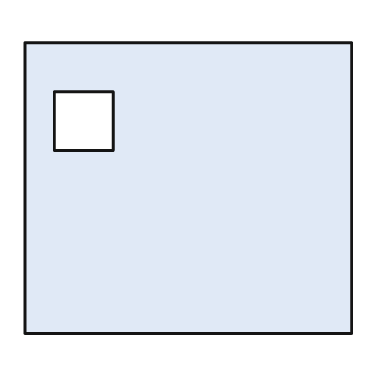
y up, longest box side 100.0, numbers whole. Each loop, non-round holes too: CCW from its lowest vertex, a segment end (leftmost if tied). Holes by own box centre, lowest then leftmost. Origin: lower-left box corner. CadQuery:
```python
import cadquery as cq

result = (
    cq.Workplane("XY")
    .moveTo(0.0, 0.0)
    .lineTo(100.0, 0.0)
    .lineTo(100.0, 89.0)
    .lineTo(0.0, 89.0)
    .close()
    .moveTo(9.0, 56.0)
    .lineTo(27.0, 56.0)
    .lineTo(27.0, 74.0)
    .lineTo(9.0, 74.0)
    .close()
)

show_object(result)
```